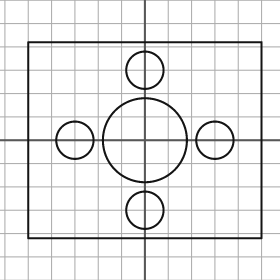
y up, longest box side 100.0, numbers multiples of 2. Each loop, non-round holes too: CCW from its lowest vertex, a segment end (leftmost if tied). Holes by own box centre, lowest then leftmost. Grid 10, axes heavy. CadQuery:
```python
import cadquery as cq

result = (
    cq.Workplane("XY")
    .moveTo(-50.0, -42.0)
    .lineTo(50.0, -42.0)
    .lineTo(50.0, 42.0)
    .lineTo(-50.0, 42.0)
    .close()
    .moveTo(0.0, -30.0)
    .circle(8.0)
    .moveTo(-30.0, 0.0)
    .circle(8.0)
    .moveTo(0.0, 0.0)
    .circle(18.0)
    .moveTo(30.0, 0.0)
    .circle(8.0)
    .moveTo(0.0, 30.0)
    .circle(8.0)
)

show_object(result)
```